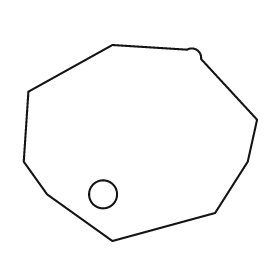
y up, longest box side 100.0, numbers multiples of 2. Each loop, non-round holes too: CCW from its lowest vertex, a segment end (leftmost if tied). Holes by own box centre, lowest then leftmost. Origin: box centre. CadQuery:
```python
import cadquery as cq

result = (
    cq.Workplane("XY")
    .moveTo(-12.0, -42.0)
    .lineTo(32.0, -30.0)
    .lineTo(46.0, -8.0)
    .lineTo(50.0, 10.0)
    .lineTo(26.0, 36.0)
    .threePointArc((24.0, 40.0), (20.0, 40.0))
    .lineTo(-12.0, 42.0)
    .lineTo(-48.0, 22.0)
    .lineTo(-50.0, -8.0)
    .lineTo(-40.0, -22.0)
    .close()
    .moveTo(-16.0, -22.0)
    .circle(6.0)
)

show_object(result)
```